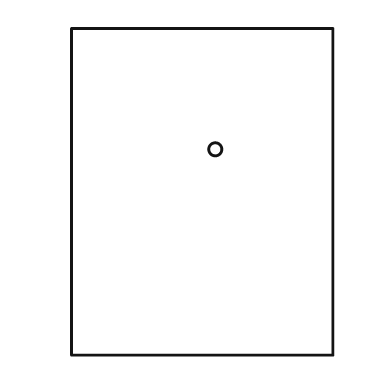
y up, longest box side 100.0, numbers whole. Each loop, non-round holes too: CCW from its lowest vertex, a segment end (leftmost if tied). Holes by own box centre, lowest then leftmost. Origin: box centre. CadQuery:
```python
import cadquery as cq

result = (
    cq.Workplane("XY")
    .moveTo(-40.0, -50.0)
    .lineTo(40.0, -50.0)
    .lineTo(40.0, 50.0)
    .lineTo(-40.0, 50.0)
    .close()
    .moveTo(4.0, 13.0)
    .circle(2.0)
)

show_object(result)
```